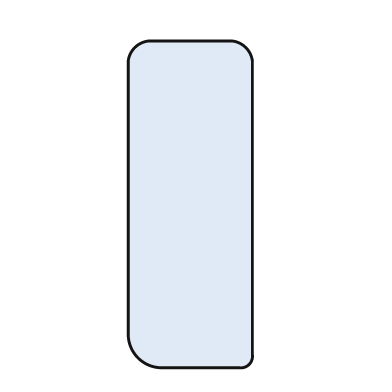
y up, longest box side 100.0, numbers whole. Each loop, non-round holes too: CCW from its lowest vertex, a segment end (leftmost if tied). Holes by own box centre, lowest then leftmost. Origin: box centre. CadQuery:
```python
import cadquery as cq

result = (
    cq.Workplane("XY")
    .moveTo(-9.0, -50.0)
    .lineTo(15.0, -50.0)
    .threePointArc((18.0, -49.0), (19.0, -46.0))
    .lineTo(19.0, 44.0)
    .threePointArc((17.0, 48.0), (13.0, 50.0))
    .lineTo(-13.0, 50.0)
    .threePointArc((-17.0, 48.0), (-19.0, 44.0))
    .lineTo(-19.0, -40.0)
    .threePointArc((-16.0, -47.0), (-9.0, -50.0))
    .close()
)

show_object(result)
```